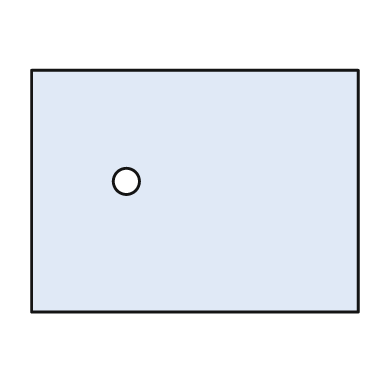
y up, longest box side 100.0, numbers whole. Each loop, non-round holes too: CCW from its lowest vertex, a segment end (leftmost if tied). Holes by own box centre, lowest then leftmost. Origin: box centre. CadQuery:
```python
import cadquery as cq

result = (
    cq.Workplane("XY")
    .moveTo(-50.0, -37.0)
    .lineTo(50.0, -37.0)
    .lineTo(50.0, 37.0)
    .lineTo(-50.0, 37.0)
    .close()
    .moveTo(-21.0, 3.0)
    .circle(4.0)
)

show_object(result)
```